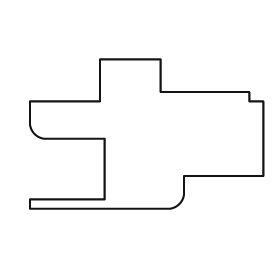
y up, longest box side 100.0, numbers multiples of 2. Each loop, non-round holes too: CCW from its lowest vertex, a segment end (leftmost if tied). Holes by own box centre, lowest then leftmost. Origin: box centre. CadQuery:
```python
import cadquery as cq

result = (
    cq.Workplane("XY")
    .moveTo(-50.0, -32.0)
    .lineTo(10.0, -32.0)
    .threePointArc((14.0, -30.0), (16.0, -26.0))
    .lineTo(16.0, -18.0)
    .lineTo(50.0, -18.0)
    .lineTo(50.0, 14.0)
    .lineTo(44.0, 14.0)
    .lineTo(44.0, 18.0)
    .lineTo(6.0, 18.0)
    .lineTo(6.0, 32.0)
    .lineTo(-20.0, 32.0)
    .lineTo(-20.0, 14.0)
    .lineTo(-50.0, 14.0)
    .lineTo(-50.0, 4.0)
    .threePointArc((-48.0, 0.0), (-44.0, -2.0))
    .lineTo(-18.0, -2.0)
    .lineTo(-18.0, -28.0)
    .lineTo(-50.0, -28.0)
    .close()
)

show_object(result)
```